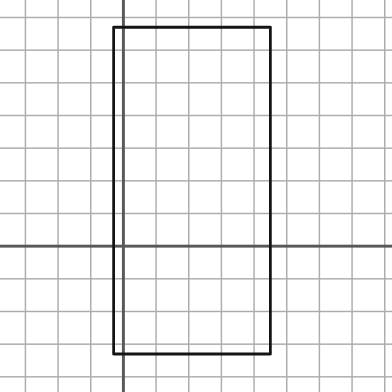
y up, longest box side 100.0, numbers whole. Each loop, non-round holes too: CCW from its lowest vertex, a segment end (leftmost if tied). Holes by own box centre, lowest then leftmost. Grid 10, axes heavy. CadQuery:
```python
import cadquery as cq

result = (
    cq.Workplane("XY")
    .moveTo(-3.0, -33.0)
    .lineTo(45.0, -33.0)
    .lineTo(45.0, 67.0)
    .lineTo(-3.0, 67.0)
    .close()
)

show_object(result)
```